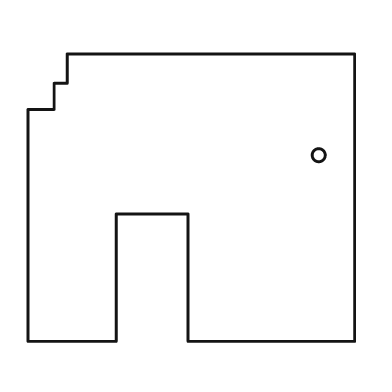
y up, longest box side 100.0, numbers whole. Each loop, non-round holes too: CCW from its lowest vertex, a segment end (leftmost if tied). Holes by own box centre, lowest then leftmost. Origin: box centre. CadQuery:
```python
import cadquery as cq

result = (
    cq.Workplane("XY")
    .moveTo(-50.0, -44.0)
    .lineTo(-23.0, -44.0)
    .lineTo(-23.0, -5.0)
    .lineTo(-1.0, -5.0)
    .lineTo(-1.0, -44.0)
    .lineTo(50.0, -44.0)
    .lineTo(50.0, 44.0)
    .lineTo(-38.0, 44.0)
    .lineTo(-38.0, 35.0)
    .lineTo(-42.0, 35.0)
    .lineTo(-42.0, 27.0)
    .lineTo(-50.0, 27.0)
    .close()
    .moveTo(39.0, 13.0)
    .circle(2.0)
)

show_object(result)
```